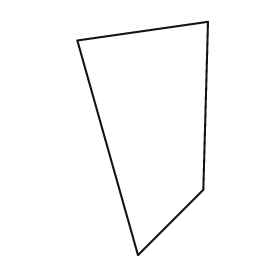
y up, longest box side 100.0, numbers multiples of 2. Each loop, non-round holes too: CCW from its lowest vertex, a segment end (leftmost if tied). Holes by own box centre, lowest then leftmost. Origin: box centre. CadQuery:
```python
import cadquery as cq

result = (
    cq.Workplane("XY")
    .moveTo(-2.0, -50.0)
    .lineTo(26.0, -22.0)
    .lineTo(28.0, 50.0)
    .lineTo(-28.0, 42.0)
    .close()
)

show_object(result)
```